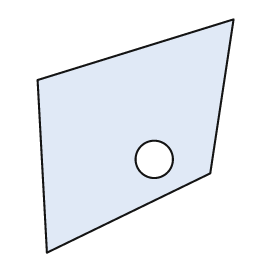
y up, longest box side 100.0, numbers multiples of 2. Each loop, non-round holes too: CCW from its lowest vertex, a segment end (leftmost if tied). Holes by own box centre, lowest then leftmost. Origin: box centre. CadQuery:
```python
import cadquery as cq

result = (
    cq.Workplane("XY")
    .moveTo(-38.0, -50.0)
    .lineTo(32.0, -16.0)
    .lineTo(42.0, 50.0)
    .lineTo(-42.0, 24.0)
    .close()
    .moveTo(8.0, -10.0)
    .circle(8.0)
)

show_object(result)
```